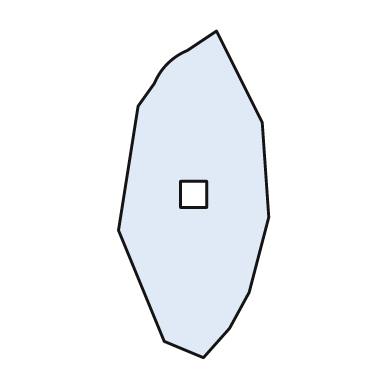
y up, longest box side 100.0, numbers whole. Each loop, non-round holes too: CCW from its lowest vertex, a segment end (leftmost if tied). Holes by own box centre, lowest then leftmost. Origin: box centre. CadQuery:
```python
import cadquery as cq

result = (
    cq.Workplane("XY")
    .moveTo(3.0, -50.0)
    .lineTo(11.0, -41.0)
    .lineTo(17.0, -30.0)
    .lineTo(23.0, -7.0)
    .lineTo(21.0, 22.0)
    .lineTo(7.0, 50.0)
    .lineTo(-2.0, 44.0)
    .threePointArc((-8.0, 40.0), (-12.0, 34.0))
    .lineTo(-17.0, 27.0)
    .lineTo(-23.0, -11.0)
    .lineTo(-9.0, -45.0)
    .close()
    .moveTo(-4.0, -4.0)
    .lineTo(4.0, -4.0)
    .lineTo(4.0, 4.0)
    .lineTo(-4.0, 4.0)
    .close()
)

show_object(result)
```